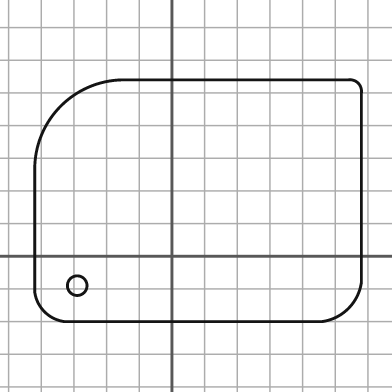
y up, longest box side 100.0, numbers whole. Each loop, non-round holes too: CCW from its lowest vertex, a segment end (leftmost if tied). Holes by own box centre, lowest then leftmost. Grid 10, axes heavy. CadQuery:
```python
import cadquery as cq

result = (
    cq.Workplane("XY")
    .moveTo(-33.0, -20.0)
    .lineTo(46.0, -20.0)
    .threePointArc((54.0, -16.0), (58.0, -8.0))
    .lineTo(58.0, 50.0)
    .threePointArc((57.0, 53.0), (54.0, 54.0))
    .lineTo(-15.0, 54.0)
    .threePointArc((-34.0, 46.0), (-42.0, 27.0))
    .lineTo(-42.0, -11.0)
    .threePointArc((-39.0, -17.0), (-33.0, -20.0))
    .close()
    .moveTo(-29.0, -9.0)
    .circle(3.0)
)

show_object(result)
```